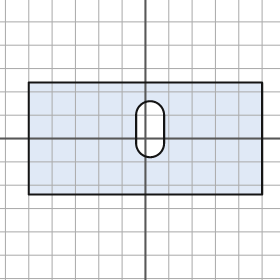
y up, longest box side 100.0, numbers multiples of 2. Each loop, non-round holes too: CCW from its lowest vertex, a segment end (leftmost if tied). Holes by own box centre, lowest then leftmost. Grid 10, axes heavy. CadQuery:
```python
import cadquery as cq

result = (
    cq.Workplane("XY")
    .moveTo(-50.0, -24.0)
    .lineTo(50.0, -24.0)
    .lineTo(50.0, 24.0)
    .lineTo(-50.0, 24.0)
    .close()
    .moveTo(-4.0, -2.0)
    .threePointArc((2.0, -8.0), (8.0, -2.0))
    .lineTo(8.0, 10.0)
    .threePointArc((2.0, 16.0), (-4.0, 10.0))
    .close()
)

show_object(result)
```